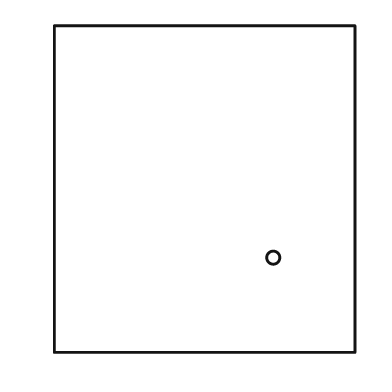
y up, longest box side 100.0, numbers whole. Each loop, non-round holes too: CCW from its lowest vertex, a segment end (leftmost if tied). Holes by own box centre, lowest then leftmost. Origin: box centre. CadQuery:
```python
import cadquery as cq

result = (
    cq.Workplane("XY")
    .moveTo(-46.0, -50.0)
    .lineTo(46.0, -50.0)
    .lineTo(46.0, 50.0)
    .lineTo(-46.0, 50.0)
    .close()
    .moveTo(21.0, -21.0)
    .circle(2.0)
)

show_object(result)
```